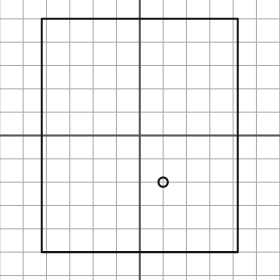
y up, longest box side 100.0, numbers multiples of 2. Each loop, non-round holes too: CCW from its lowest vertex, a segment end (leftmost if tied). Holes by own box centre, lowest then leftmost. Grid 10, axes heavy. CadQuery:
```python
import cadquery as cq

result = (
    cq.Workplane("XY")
    .moveTo(-42.0, -50.0)
    .lineTo(42.0, -50.0)
    .lineTo(42.0, 50.0)
    .lineTo(-42.0, 50.0)
    .close()
    .moveTo(10.0, -20.0)
    .circle(2.0)
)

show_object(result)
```